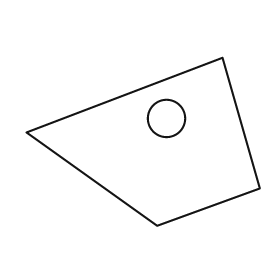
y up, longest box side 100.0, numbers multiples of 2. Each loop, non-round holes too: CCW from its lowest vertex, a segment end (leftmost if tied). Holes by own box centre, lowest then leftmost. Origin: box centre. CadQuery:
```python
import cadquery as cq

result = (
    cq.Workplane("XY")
    .moveTo(6.0, -36.0)
    .lineTo(50.0, -20.0)
    .lineTo(34.0, 36.0)
    .lineTo(-50.0, 4.0)
    .close()
    .moveTo(10.0, 10.0)
    .circle(8.0)
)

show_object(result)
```